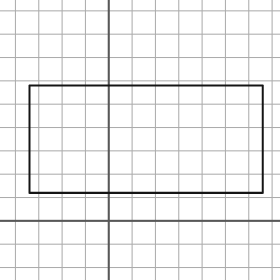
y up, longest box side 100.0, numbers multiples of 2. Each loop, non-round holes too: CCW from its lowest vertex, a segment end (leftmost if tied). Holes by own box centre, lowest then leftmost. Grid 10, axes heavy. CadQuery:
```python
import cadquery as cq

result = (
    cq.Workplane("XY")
    .moveTo(-34.0, 12.0)
    .lineTo(66.0, 12.0)
    .lineTo(66.0, 58.0)
    .lineTo(-34.0, 58.0)
    .close()
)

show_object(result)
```